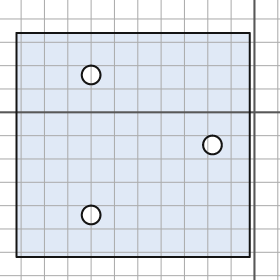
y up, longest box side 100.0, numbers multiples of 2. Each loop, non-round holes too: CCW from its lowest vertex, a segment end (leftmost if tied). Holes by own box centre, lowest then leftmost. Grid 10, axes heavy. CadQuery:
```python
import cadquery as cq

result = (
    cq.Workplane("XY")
    .moveTo(-102.0, -62.0)
    .lineTo(-2.0, -62.0)
    .lineTo(-2.0, 34.0)
    .lineTo(-102.0, 34.0)
    .close()
    .moveTo(-70.0, -44.0)
    .circle(4.0)
    .moveTo(-18.0, -14.0)
    .circle(4.0)
    .moveTo(-70.0, 16.0)
    .circle(4.0)
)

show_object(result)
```